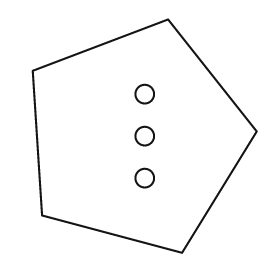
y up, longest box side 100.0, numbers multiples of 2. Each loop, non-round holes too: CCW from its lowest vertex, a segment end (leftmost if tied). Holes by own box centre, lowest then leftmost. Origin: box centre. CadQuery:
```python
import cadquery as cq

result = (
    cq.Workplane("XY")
    .moveTo(16.0, -50.0)
    .lineTo(48.0, 2.0)
    .lineTo(10.0, 50.0)
    .lineTo(-48.0, 28.0)
    .lineTo(-44.0, -34.0)
    .close()
    .moveTo(0.0, -18.0)
    .circle(4.0)
    .moveTo(0.0, 0.0)
    .circle(4.0)
    .moveTo(0.0, 18.0)
    .circle(4.0)
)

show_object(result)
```